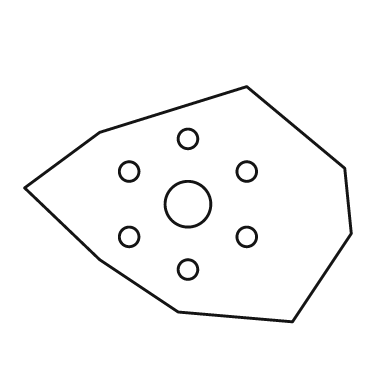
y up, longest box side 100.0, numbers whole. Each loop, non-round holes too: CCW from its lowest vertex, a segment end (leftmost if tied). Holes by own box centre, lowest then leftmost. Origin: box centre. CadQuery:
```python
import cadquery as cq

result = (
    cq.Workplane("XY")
    .moveTo(32.0, -36.0)
    .lineTo(50.0, -9.0)
    .lineTo(48.0, 11.0)
    .lineTo(18.0, 36.0)
    .lineTo(-27.0, 22.0)
    .lineTo(-50.0, 5.0)
    .lineTo(-27.0, -17.0)
    .lineTo(-3.0, -33.0)
    .close()
    .moveTo(0.0, -20.0)
    .circle(3.0)
    .moveTo(-18.0, -10.0)
    .circle(3.0)
    .moveTo(18.0, -10.0)
    .circle(3.0)
    .moveTo(0.0, 0.0)
    .circle(7.0)
    .moveTo(-18.0, 10.0)
    .circle(3.0)
    .moveTo(18.0, 10.0)
    .circle(3.0)
    .moveTo(0.0, 20.0)
    .circle(3.0)
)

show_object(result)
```